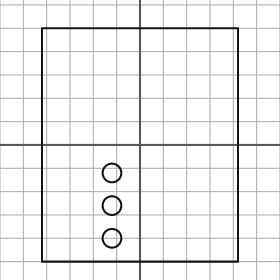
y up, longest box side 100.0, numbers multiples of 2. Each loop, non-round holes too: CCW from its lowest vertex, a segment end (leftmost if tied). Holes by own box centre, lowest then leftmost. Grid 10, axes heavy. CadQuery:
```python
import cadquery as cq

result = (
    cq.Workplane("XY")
    .moveTo(-42.0, -50.0)
    .lineTo(42.0, -50.0)
    .lineTo(42.0, 50.0)
    .lineTo(-42.0, 50.0)
    .close()
    .moveTo(-12.0, -40.0)
    .circle(4.0)
    .moveTo(-12.0, -26.0)
    .circle(4.0)
    .moveTo(-12.0, -12.0)
    .circle(4.0)
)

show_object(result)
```